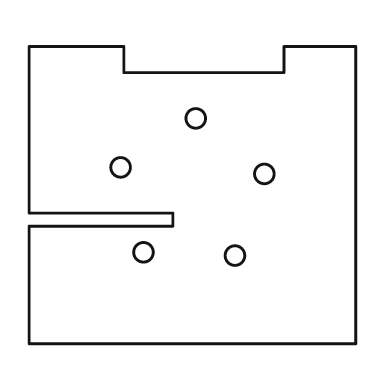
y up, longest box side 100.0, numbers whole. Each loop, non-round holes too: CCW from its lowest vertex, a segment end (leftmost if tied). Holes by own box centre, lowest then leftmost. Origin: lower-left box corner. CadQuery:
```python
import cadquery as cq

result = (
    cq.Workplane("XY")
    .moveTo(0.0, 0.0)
    .lineTo(100.0, 0.0)
    .lineTo(100.0, 91.0)
    .lineTo(78.0, 91.0)
    .lineTo(78.0, 83.0)
    .lineTo(29.0, 83.0)
    .lineTo(29.0, 91.0)
    .lineTo(0.0, 91.0)
    .lineTo(0.0, 40.0)
    .lineTo(44.0, 40.0)
    .lineTo(44.0, 36.0)
    .lineTo(0.0, 36.0)
    .close()
    .moveTo(63.0, 27.0)
    .circle(3.0)
    .moveTo(35.0, 28.0)
    .circle(3.0)
    .moveTo(72.0, 52.0)
    .circle(3.0)
    .moveTo(28.0, 54.0)
    .circle(3.0)
    .moveTo(51.0, 69.0)
    .circle(3.0)
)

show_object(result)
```